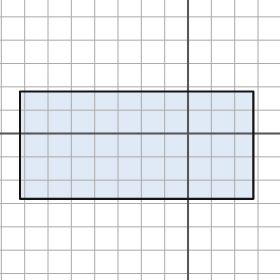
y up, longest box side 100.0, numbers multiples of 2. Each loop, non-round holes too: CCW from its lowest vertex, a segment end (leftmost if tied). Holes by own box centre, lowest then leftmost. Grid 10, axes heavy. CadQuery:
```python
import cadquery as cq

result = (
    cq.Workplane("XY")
    .moveTo(-72.0, -28.0)
    .lineTo(28.0, -28.0)
    .lineTo(28.0, 18.0)
    .lineTo(-72.0, 18.0)
    .close()
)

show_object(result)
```